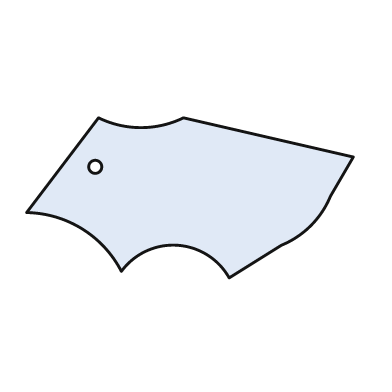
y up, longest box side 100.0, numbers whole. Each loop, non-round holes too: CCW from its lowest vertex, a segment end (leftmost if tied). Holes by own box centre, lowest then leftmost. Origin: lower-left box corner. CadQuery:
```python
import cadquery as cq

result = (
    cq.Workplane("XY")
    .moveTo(62.0, 0.0)
    .lineTo(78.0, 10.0)
    .threePointArc((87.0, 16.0), (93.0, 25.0))
    .lineTo(100.0, 37.0)
    .lineTo(48.0, 49.0)
    .threePointArc((35.0, 46.0), (22.0, 49.0))
    .lineTo(0.0, 20.0)
    .threePointArc((17.0, 15.0), (29.0, 2.0))
    .threePointArc((46.0, 10.0), (62.0, 0.0))
    .close()
    .moveTo(21.0, 34.0)
    .circle(2.0)
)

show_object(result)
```